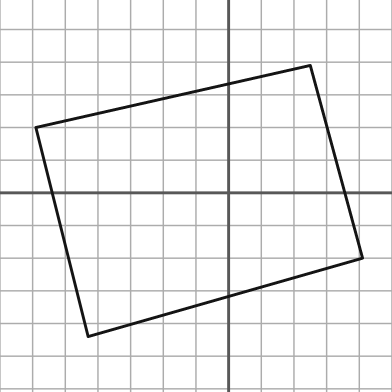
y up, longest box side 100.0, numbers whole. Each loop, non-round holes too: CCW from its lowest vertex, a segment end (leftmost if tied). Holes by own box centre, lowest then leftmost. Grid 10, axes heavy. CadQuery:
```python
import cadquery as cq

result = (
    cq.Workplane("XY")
    .moveTo(-43.0, -44.0)
    .lineTo(41.0, -20.0)
    .lineTo(25.0, 39.0)
    .lineTo(-59.0, 20.0)
    .close()
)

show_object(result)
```